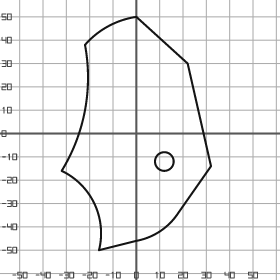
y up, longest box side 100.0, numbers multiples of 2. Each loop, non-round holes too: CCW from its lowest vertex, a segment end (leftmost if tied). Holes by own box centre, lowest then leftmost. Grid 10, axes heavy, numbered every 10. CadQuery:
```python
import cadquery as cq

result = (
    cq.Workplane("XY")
    .moveTo(-16.0, -50.0)
    .lineTo(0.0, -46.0)
    .threePointArc((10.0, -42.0), (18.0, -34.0))
    .lineTo(32.0, -14.0)
    .lineTo(22.0, 30.0)
    .lineTo(0.0, 50.0)
    .threePointArc((-12.0, 46.0), (-22.0, 38.0))
    .threePointArc((-22.0, 10.0), (-32.0, -16.0))
    .threePointArc((-18.0, -30.0), (-16.0, -50.0))
    .close()
    .moveTo(12.0, -12.0)
    .circle(4.0)
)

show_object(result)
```